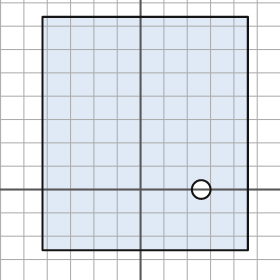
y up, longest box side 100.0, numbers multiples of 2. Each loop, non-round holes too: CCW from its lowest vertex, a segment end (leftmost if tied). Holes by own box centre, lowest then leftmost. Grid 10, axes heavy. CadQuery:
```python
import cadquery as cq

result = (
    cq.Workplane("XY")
    .moveTo(-42.0, -26.0)
    .lineTo(46.0, -26.0)
    .lineTo(46.0, 74.0)
    .lineTo(-42.0, 74.0)
    .close()
    .moveTo(26.0, 0.0)
    .circle(4.0)
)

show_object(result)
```